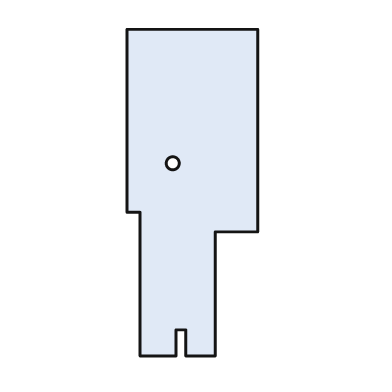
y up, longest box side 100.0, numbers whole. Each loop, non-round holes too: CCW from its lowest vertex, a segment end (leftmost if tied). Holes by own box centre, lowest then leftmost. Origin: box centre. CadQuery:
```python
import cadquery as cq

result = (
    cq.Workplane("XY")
    .moveTo(-16.0, -50.0)
    .lineTo(-5.0, -50.0)
    .lineTo(-5.0, -42.0)
    .lineTo(-2.0, -42.0)
    .lineTo(-2.0, -50.0)
    .lineTo(7.0, -50.0)
    .lineTo(7.0, -12.0)
    .lineTo(20.0, -12.0)
    .lineTo(20.0, 50.0)
    .lineTo(-20.0, 50.0)
    .lineTo(-20.0, -6.0)
    .lineTo(-16.0, -6.0)
    .close()
    .moveTo(-6.0, 9.0)
    .circle(2.0)
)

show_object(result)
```